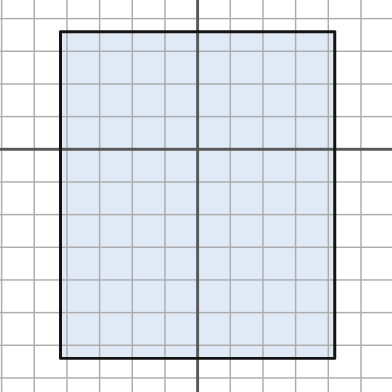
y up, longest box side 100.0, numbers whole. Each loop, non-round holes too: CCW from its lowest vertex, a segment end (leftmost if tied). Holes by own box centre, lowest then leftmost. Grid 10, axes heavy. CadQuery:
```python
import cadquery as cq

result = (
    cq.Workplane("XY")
    .moveTo(-42.0, -64.0)
    .lineTo(42.0, -64.0)
    .lineTo(42.0, 36.0)
    .lineTo(-42.0, 36.0)
    .close()
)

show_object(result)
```